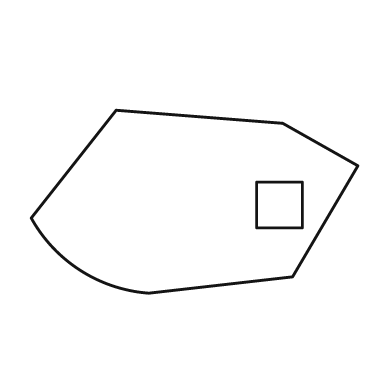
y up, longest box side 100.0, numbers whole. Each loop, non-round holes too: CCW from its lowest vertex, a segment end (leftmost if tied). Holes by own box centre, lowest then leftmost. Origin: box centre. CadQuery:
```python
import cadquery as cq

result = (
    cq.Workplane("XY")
    .moveTo(-14.0, -28.0)
    .lineTo(30.0, -23.0)
    .lineTo(50.0, 11.0)
    .lineTo(27.0, 24.0)
    .lineTo(-24.0, 28.0)
    .lineTo(-50.0, -5.0)
    .threePointArc((-35.0, -21.0), (-14.0, -28.0))
    .close()
    .moveTo(19.0, -8.0)
    .lineTo(33.0, -8.0)
    .lineTo(33.0, 6.0)
    .lineTo(19.0, 6.0)
    .close()
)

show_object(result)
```